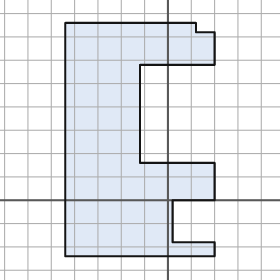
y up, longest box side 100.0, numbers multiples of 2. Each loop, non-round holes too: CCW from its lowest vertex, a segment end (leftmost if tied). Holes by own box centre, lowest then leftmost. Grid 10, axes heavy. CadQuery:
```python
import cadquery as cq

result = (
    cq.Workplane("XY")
    .moveTo(-44.0, -24.0)
    .lineTo(20.0, -24.0)
    .lineTo(20.0, -18.0)
    .lineTo(2.0, -18.0)
    .lineTo(2.0, 0.0)
    .lineTo(20.0, 0.0)
    .lineTo(20.0, 16.0)
    .lineTo(-12.0, 16.0)
    .lineTo(-12.0, 58.0)
    .lineTo(20.0, 58.0)
    .lineTo(20.0, 72.0)
    .lineTo(12.0, 72.0)
    .lineTo(12.0, 76.0)
    .lineTo(-44.0, 76.0)
    .close()
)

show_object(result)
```